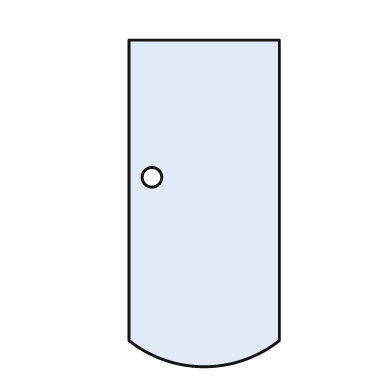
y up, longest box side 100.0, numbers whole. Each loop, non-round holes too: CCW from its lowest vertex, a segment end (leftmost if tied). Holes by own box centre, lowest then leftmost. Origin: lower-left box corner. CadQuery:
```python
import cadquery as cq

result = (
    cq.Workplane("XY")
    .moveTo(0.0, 8.0)
    .threePointArc((23.0, 0.0), (46.0, 8.0))
    .lineTo(46.0, 100.0)
    .lineTo(0.0, 100.0)
    .close()
    .moveTo(7.0, 58.0)
    .circle(3.0)
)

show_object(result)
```